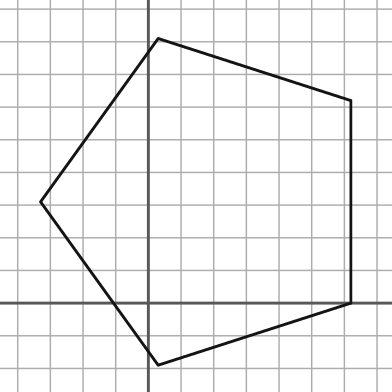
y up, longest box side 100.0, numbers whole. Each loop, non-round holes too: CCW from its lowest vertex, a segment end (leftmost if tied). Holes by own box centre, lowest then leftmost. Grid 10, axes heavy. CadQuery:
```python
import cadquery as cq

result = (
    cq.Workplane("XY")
    .moveTo(3.0, -19.0)
    .lineTo(62.0, 0.0)
    .lineTo(62.0, 62.0)
    .lineTo(3.0, 81.0)
    .lineTo(-33.0, 31.0)
    .close()
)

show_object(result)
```